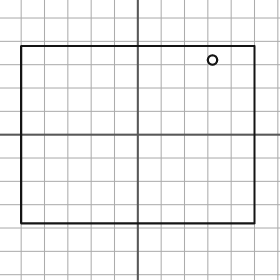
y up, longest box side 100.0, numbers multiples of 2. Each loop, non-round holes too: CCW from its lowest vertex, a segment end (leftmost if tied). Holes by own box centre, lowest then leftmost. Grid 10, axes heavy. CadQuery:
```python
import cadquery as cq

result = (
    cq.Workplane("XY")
    .moveTo(-50.0, -38.0)
    .lineTo(50.0, -38.0)
    .lineTo(50.0, 38.0)
    .lineTo(-50.0, 38.0)
    .close()
    .moveTo(32.0, 32.0)
    .circle(2.0)
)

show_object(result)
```